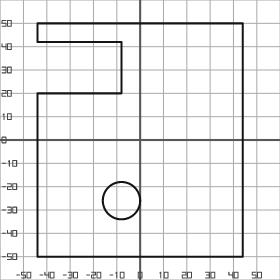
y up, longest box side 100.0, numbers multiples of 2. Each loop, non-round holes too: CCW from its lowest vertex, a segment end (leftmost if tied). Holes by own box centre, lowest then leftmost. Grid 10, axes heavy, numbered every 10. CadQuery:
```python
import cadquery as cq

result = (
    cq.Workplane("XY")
    .moveTo(-44.0, -50.0)
    .lineTo(44.0, -50.0)
    .lineTo(44.0, 50.0)
    .lineTo(-44.0, 50.0)
    .lineTo(-44.0, 42.0)
    .lineTo(-8.0, 42.0)
    .lineTo(-8.0, 20.0)
    .lineTo(-44.0, 20.0)
    .close()
    .moveTo(-8.0, -26.0)
    .circle(8.0)
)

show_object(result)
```